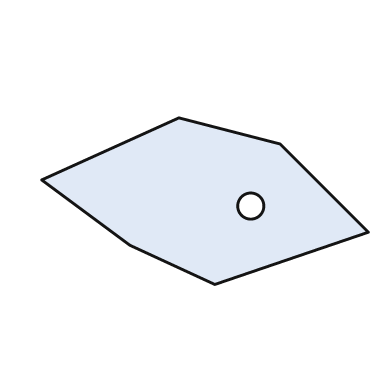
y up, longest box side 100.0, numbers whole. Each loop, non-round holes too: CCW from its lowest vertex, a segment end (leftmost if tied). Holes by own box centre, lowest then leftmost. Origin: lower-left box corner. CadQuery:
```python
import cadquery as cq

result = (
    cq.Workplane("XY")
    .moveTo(53.0, 0.0)
    .lineTo(100.0, 16.0)
    .lineTo(73.0, 43.0)
    .lineTo(42.0, 51.0)
    .lineTo(0.0, 32.0)
    .lineTo(27.0, 12.0)
    .close()
    .moveTo(64.0, 24.0)
    .circle(4.0)
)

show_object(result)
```